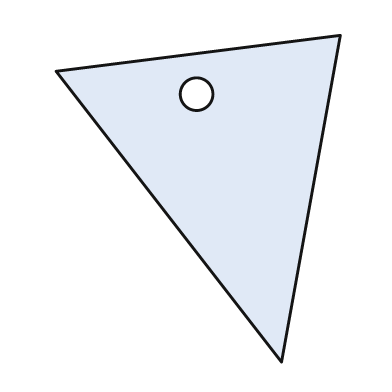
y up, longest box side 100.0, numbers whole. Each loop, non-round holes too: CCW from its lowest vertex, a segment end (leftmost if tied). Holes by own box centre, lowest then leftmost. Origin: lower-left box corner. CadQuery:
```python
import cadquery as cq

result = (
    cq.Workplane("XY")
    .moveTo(69.0, 0.0)
    .lineTo(87.0, 100.0)
    .lineTo(0.0, 89.0)
    .close()
    .moveTo(43.0, 82.0)
    .circle(5.0)
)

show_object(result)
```